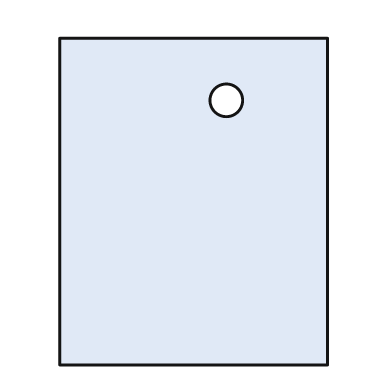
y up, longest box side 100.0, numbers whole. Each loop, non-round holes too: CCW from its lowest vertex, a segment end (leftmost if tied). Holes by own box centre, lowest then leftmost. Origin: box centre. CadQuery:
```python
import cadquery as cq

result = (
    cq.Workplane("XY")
    .moveTo(-41.0, -50.0)
    .lineTo(41.0, -50.0)
    .lineTo(41.0, 50.0)
    .lineTo(-41.0, 50.0)
    .close()
    .moveTo(10.0, 31.0)
    .circle(5.0)
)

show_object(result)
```